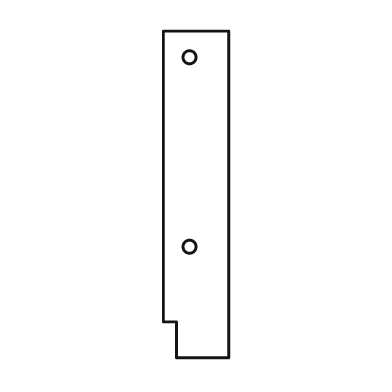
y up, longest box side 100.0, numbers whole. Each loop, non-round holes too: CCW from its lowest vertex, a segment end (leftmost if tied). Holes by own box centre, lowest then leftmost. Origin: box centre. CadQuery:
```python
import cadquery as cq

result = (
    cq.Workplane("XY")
    .moveTo(-6.0, -50.0)
    .lineTo(10.0, -50.0)
    .lineTo(10.0, 50.0)
    .lineTo(-10.0, 50.0)
    .lineTo(-10.0, -39.0)
    .lineTo(-6.0, -39.0)
    .close()
    .moveTo(-2.0, -16.0)
    .circle(2.0)
    .moveTo(-2.0, 42.0)
    .circle(2.0)
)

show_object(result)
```